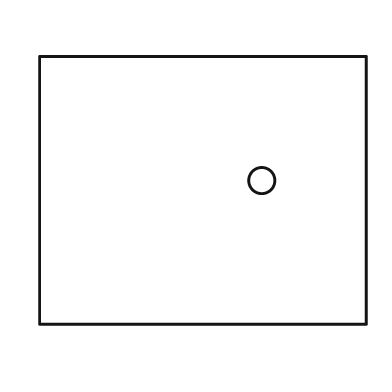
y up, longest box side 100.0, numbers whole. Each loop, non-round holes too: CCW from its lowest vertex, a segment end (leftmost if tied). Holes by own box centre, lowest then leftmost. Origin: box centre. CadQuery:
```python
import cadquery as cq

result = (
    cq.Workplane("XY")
    .moveTo(-50.0, -41.0)
    .lineTo(50.0, -41.0)
    .lineTo(50.0, 41.0)
    .lineTo(-50.0, 41.0)
    .close()
    .moveTo(18.0, 3.0)
    .circle(4.0)
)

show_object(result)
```